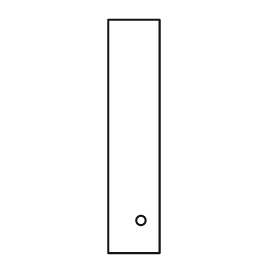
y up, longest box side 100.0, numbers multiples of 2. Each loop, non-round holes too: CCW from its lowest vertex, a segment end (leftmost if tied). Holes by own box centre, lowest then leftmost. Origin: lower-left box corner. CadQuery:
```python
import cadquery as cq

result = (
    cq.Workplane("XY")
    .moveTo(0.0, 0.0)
    .lineTo(22.0, 0.0)
    .lineTo(22.0, 100.0)
    .lineTo(0.0, 100.0)
    .close()
    .moveTo(14.0, 14.0)
    .circle(2.0)
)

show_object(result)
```